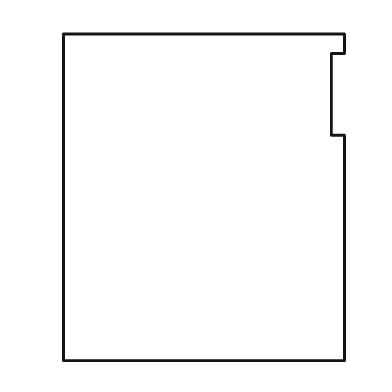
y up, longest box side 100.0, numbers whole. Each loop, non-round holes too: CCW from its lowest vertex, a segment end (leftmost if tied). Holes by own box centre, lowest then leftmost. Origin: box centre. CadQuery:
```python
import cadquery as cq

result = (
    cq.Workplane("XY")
    .moveTo(-43.0, -50.0)
    .lineTo(43.0, -50.0)
    .lineTo(43.0, 19.0)
    .lineTo(39.0, 19.0)
    .lineTo(39.0, 44.0)
    .lineTo(43.0, 44.0)
    .lineTo(43.0, 50.0)
    .lineTo(-43.0, 50.0)
    .close()
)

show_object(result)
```